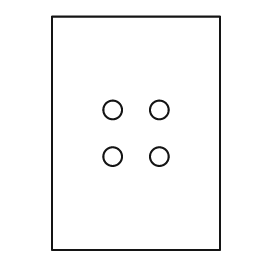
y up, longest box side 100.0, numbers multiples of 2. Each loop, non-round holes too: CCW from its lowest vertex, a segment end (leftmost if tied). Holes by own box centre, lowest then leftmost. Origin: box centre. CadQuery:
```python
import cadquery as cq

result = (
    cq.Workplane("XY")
    .moveTo(-36.0, -50.0)
    .lineTo(36.0, -50.0)
    .lineTo(36.0, 50.0)
    .lineTo(-36.0, 50.0)
    .close()
    .moveTo(-10.0, -10.0)
    .circle(4.0)
    .moveTo(10.0, -10.0)
    .circle(4.0)
    .moveTo(-10.0, 10.0)
    .circle(4.0)
    .moveTo(10.0, 10.0)
    .circle(4.0)
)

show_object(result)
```